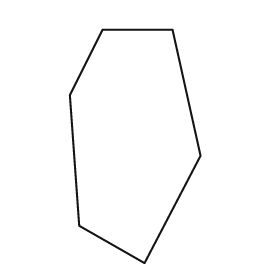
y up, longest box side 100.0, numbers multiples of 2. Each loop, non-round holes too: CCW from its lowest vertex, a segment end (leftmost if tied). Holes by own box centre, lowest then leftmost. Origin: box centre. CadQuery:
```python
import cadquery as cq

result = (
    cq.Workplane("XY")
    .moveTo(4.0, -50.0)
    .lineTo(28.0, -4.0)
    .lineTo(16.0, 50.0)
    .lineTo(-14.0, 50.0)
    .lineTo(-28.0, 22.0)
    .lineTo(-24.0, -34.0)
    .close()
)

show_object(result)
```